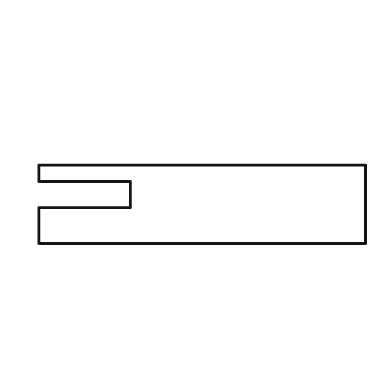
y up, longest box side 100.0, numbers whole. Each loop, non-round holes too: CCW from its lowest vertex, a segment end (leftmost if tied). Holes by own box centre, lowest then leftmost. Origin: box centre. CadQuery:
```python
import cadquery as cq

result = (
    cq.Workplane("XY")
    .moveTo(-50.0, -12.0)
    .lineTo(50.0, -12.0)
    .lineTo(50.0, 12.0)
    .lineTo(-50.0, 12.0)
    .lineTo(-50.0, 7.0)
    .lineTo(-22.0, 7.0)
    .lineTo(-22.0, -1.0)
    .lineTo(-50.0, -1.0)
    .close()
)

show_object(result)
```